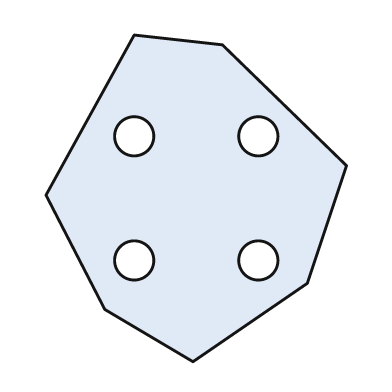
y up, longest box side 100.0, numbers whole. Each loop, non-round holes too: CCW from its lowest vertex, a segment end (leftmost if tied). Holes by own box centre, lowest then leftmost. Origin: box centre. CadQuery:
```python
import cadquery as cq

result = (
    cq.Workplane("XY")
    .moveTo(-1.0, -50.0)
    .lineTo(34.0, -26.0)
    .lineTo(46.0, 10.0)
    .lineTo(8.0, 47.0)
    .lineTo(-19.0, 50.0)
    .lineTo(-46.0, 1.0)
    .lineTo(-28.0, -34.0)
    .close()
    .moveTo(-19.0, -19.0)
    .circle(6.0)
    .moveTo(19.0, -19.0)
    .circle(6.0)
    .moveTo(-19.0, 19.0)
    .circle(6.0)
    .moveTo(19.0, 19.0)
    .circle(6.0)
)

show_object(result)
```